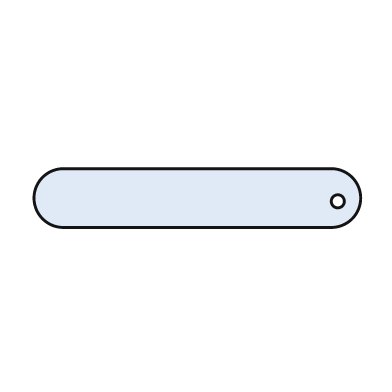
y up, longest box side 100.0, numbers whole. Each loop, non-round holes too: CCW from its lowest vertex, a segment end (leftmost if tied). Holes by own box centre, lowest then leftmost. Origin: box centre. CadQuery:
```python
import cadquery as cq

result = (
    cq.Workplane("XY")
    .moveTo(-41.0, -9.0)
    .lineTo(41.0, -9.0)
    .threePointArc((50.0, 0.0), (41.0, 9.0))
    .lineTo(-41.0, 9.0)
    .threePointArc((-50.0, 0.0), (-41.0, -9.0))
    .close()
    .moveTo(43.0, -1.0)
    .circle(2.0)
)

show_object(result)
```